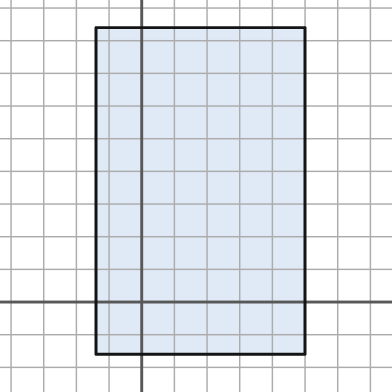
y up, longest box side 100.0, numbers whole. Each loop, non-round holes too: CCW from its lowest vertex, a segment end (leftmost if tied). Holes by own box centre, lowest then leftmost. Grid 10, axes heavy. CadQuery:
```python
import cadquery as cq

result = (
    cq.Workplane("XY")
    .moveTo(-14.0, -16.0)
    .lineTo(50.0, -16.0)
    .lineTo(50.0, 84.0)
    .lineTo(-14.0, 84.0)
    .close()
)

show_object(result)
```